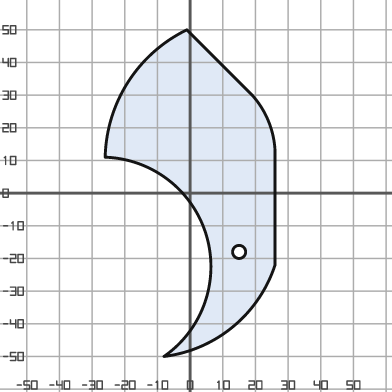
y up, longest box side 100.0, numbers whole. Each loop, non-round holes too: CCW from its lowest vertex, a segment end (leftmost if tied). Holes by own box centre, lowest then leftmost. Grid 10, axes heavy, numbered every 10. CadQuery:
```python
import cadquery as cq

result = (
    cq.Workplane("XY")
    .moveTo(-8.0, -50.0)
    .threePointArc((13.0, -41.0), (26.0, -22.0))
    .lineTo(26.0, 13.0)
    .threePointArc((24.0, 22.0), (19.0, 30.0))
    .lineTo(-1.0, 50.0)
    .threePointArc((-19.0, 34.0), (-26.0, 11.0))
    .threePointArc((5.0, -13.0), (-8.0, -50.0))
    .close()
    .moveTo(15.0, -18.0)
    .circle(2.0)
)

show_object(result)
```